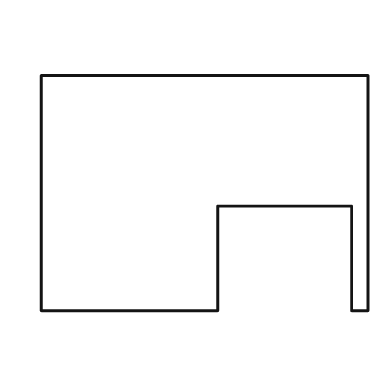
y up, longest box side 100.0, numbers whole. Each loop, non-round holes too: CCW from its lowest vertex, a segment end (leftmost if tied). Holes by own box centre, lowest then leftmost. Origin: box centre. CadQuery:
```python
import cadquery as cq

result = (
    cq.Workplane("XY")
    .moveTo(-50.0, -36.0)
    .lineTo(4.0, -36.0)
    .lineTo(4.0, -4.0)
    .lineTo(45.0, -4.0)
    .lineTo(45.0, -36.0)
    .lineTo(50.0, -36.0)
    .lineTo(50.0, 36.0)
    .lineTo(-50.0, 36.0)
    .close()
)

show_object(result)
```